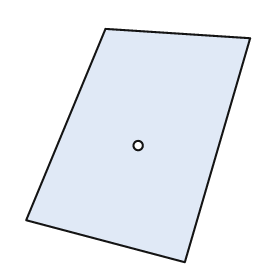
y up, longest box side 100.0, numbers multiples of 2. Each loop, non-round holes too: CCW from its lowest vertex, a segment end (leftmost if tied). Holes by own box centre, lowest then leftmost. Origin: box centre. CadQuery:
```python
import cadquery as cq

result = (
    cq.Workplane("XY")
    .moveTo(20.0, -50.0)
    .lineTo(48.0, 46.0)
    .lineTo(-14.0, 50.0)
    .lineTo(-48.0, -32.0)
    .close()
    .moveTo(0.0, 0.0)
    .circle(2.0)
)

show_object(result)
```